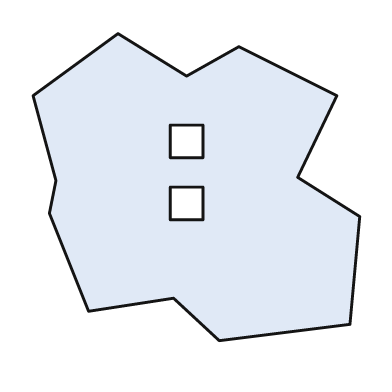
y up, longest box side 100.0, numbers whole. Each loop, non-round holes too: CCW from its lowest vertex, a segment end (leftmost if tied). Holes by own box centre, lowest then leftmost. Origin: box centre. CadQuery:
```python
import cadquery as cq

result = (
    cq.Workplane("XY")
    .moveTo(7.0, -47.0)
    .lineTo(47.0, -42.0)
    .lineTo(50.0, -9.0)
    .lineTo(31.0, 3.0)
    .lineTo(43.0, 28.0)
    .lineTo(13.0, 43.0)
    .lineTo(-3.0, 34.0)
    .lineTo(-24.0, 47.0)
    .lineTo(-50.0, 28.0)
    .lineTo(-43.0, 2.0)
    .lineTo(-45.0, -8.0)
    .lineTo(-33.0, -38.0)
    .lineTo(-7.0, -34.0)
    .close()
    .moveTo(-8.0, -10.0)
    .lineTo(2.0, -10.0)
    .lineTo(2.0, 0.0)
    .lineTo(-8.0, 0.0)
    .close()
    .moveTo(-8.0, 9.0)
    .lineTo(2.0, 9.0)
    .lineTo(2.0, 19.0)
    .lineTo(-8.0, 19.0)
    .close()
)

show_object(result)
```